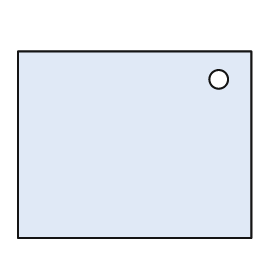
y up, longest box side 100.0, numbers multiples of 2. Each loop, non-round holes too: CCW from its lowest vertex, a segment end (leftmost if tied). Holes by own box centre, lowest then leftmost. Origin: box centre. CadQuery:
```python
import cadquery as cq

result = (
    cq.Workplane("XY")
    .moveTo(-50.0, -40.0)
    .lineTo(50.0, -40.0)
    .lineTo(50.0, 40.0)
    .lineTo(-50.0, 40.0)
    .close()
    .moveTo(36.0, 28.0)
    .circle(4.0)
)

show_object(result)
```